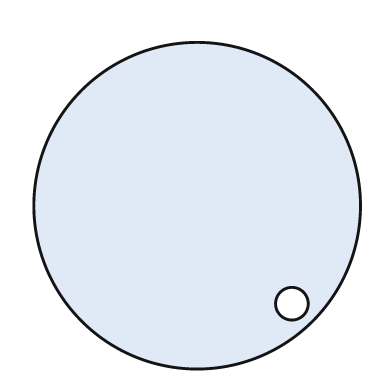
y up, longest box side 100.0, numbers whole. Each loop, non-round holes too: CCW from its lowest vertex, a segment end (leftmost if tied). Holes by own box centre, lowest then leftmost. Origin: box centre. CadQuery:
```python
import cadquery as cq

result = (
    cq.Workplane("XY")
    .moveTo(0.0, 0.0)
    .circle(50.0)
    .moveTo(29.0, -30.0)
    .circle(5.0)
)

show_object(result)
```